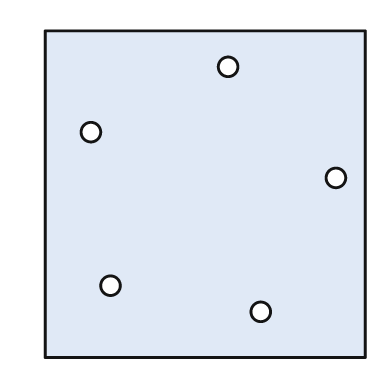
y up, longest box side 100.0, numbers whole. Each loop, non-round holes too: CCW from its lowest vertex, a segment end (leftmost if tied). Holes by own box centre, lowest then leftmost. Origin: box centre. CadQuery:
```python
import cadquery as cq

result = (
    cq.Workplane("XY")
    .moveTo(-49.0, -50.0)
    .lineTo(49.0, -50.0)
    .lineTo(49.0, 50.0)
    .lineTo(-49.0, 50.0)
    .close()
    .moveTo(17.0, -36.0)
    .circle(3.0)
    .moveTo(-29.0, -28.0)
    .circle(3.0)
    .moveTo(40.0, 5.0)
    .circle(3.0)
    .moveTo(-35.0, 19.0)
    .circle(3.0)
    .moveTo(7.0, 39.0)
    .circle(3.0)
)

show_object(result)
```